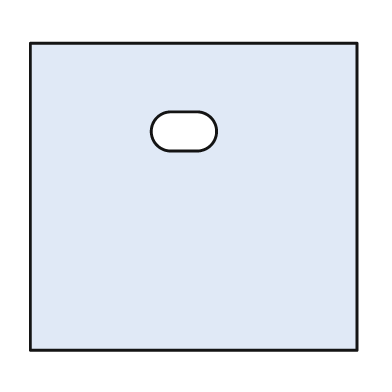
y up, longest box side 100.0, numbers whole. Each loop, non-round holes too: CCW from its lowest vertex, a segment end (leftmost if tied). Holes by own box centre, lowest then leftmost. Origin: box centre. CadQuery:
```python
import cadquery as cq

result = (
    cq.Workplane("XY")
    .moveTo(-50.0, -47.0)
    .lineTo(50.0, -47.0)
    .lineTo(50.0, 47.0)
    .lineTo(-50.0, 47.0)
    .close()
    .moveTo(-7.0, 14.0)
    .lineTo(1.0, 14.0)
    .threePointArc((7.0, 20.0), (1.0, 26.0))
    .lineTo(-7.0, 26.0)
    .threePointArc((-13.0, 20.0), (-7.0, 14.0))
    .close()
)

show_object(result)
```